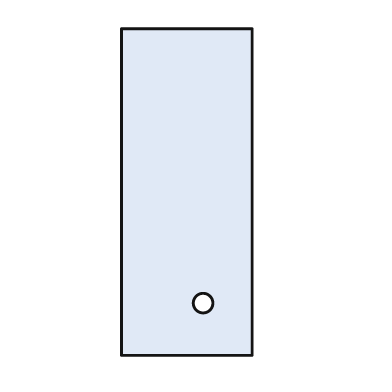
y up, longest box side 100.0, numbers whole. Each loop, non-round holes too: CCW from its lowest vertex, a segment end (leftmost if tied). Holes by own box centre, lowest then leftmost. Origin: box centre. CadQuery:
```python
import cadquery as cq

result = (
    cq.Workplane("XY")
    .moveTo(-20.0, -50.0)
    .lineTo(20.0, -50.0)
    .lineTo(20.0, 50.0)
    .lineTo(-20.0, 50.0)
    .close()
    .moveTo(5.0, -34.0)
    .circle(3.0)
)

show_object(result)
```